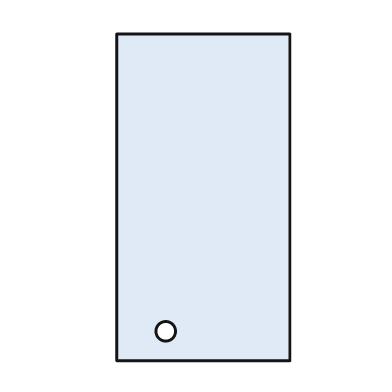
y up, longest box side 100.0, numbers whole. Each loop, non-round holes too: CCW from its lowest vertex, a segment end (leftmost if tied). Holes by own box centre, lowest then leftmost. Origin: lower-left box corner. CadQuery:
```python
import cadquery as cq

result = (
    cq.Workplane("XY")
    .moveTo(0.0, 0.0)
    .lineTo(53.0, 0.0)
    .lineTo(53.0, 100.0)
    .lineTo(0.0, 100.0)
    .close()
    .moveTo(15.0, 9.0)
    .circle(3.0)
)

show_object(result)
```